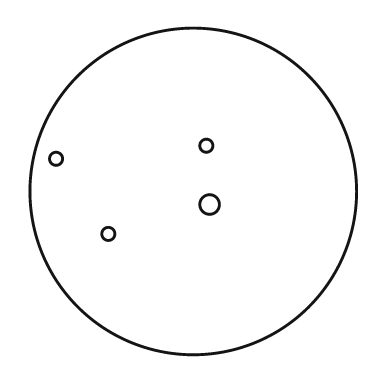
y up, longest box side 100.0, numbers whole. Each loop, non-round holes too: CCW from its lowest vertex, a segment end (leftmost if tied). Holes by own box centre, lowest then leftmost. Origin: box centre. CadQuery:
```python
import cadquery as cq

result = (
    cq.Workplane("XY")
    .moveTo(0.0, 0.0)
    .circle(50.0)
    .moveTo(-26.0, -13.0)
    .circle(2.0)
    .moveTo(5.0, -4.0)
    .circle(3.0)
    .moveTo(-42.0, 10.0)
    .circle(2.0)
    .moveTo(4.0, 14.0)
    .circle(2.0)
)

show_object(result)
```